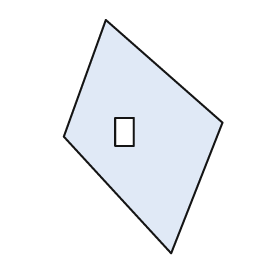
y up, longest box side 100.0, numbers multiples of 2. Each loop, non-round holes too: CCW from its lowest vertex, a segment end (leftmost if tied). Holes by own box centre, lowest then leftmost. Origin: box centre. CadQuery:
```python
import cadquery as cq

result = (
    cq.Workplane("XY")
    .moveTo(12.0, -50.0)
    .lineTo(34.0, 6.0)
    .lineTo(-16.0, 50.0)
    .lineTo(-34.0, 0.0)
    .close()
    .moveTo(-12.0, -4.0)
    .lineTo(-4.0, -4.0)
    .lineTo(-4.0, 8.0)
    .lineTo(-12.0, 8.0)
    .close()
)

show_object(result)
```